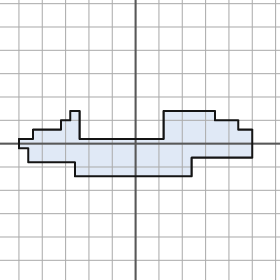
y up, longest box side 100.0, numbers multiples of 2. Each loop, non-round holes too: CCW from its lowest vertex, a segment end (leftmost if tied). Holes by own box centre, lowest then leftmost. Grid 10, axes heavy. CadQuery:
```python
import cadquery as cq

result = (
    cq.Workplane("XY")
    .moveTo(-26.0, -14.0)
    .lineTo(24.0, -14.0)
    .lineTo(24.0, -6.0)
    .lineTo(50.0, -6.0)
    .lineTo(50.0, 6.0)
    .lineTo(44.0, 6.0)
    .lineTo(44.0, 10.0)
    .lineTo(34.0, 10.0)
    .lineTo(34.0, 14.0)
    .lineTo(12.0, 14.0)
    .lineTo(12.0, 2.0)
    .lineTo(-24.0, 2.0)
    .lineTo(-24.0, 14.0)
    .lineTo(-28.0, 14.0)
    .lineTo(-28.0, 10.0)
    .lineTo(-32.0, 10.0)
    .lineTo(-32.0, 6.0)
    .lineTo(-44.0, 6.0)
    .lineTo(-44.0, 2.0)
    .lineTo(-50.0, 2.0)
    .lineTo(-50.0, -2.0)
    .lineTo(-46.0, -2.0)
    .lineTo(-46.0, -8.0)
    .lineTo(-26.0, -8.0)
    .close()
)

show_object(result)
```